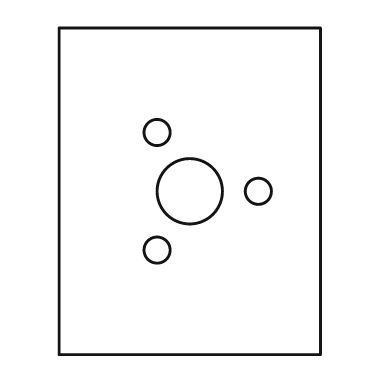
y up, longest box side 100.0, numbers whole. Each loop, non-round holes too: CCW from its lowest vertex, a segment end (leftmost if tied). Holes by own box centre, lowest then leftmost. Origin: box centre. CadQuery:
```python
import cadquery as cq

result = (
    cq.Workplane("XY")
    .moveTo(-40.0, -50.0)
    .lineTo(40.0, -50.0)
    .lineTo(40.0, 50.0)
    .lineTo(-40.0, 50.0)
    .close()
    .moveTo(-10.0, -18.0)
    .circle(4.0)
    .moveTo(0.0, 0.0)
    .circle(10.0)
    .moveTo(21.0, 0.0)
    .circle(4.0)
    .moveTo(-10.0, 18.0)
    .circle(4.0)
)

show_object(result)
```